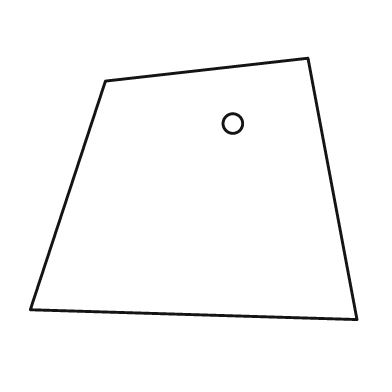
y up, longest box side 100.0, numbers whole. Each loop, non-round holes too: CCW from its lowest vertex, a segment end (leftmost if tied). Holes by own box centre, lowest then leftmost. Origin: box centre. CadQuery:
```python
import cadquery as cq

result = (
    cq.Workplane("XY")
    .moveTo(50.0, -40.0)
    .lineTo(35.0, 40.0)
    .lineTo(-27.0, 33.0)
    .lineTo(-50.0, -37.0)
    .close()
    .moveTo(12.0, 20.0)
    .circle(3.0)
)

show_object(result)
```